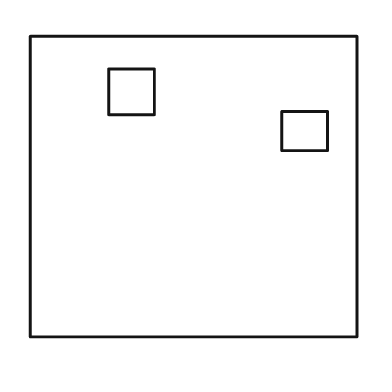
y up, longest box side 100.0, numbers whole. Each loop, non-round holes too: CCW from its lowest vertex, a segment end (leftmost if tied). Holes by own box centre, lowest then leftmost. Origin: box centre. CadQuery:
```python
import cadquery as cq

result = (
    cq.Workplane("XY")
    .moveTo(-50.0, -46.0)
    .lineTo(50.0, -46.0)
    .lineTo(50.0, 46.0)
    .lineTo(-50.0, 46.0)
    .close()
    .moveTo(27.0, 11.0)
    .lineTo(41.0, 11.0)
    .lineTo(41.0, 23.0)
    .lineTo(27.0, 23.0)
    .close()
    .moveTo(-26.0, 22.0)
    .lineTo(-12.0, 22.0)
    .lineTo(-12.0, 36.0)
    .lineTo(-26.0, 36.0)
    .close()
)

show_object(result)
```